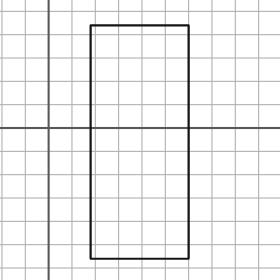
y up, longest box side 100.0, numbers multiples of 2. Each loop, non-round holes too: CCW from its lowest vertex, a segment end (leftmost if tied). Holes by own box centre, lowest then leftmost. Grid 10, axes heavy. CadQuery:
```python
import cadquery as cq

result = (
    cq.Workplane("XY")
    .moveTo(18.0, -56.0)
    .lineTo(60.0, -56.0)
    .lineTo(60.0, 44.0)
    .lineTo(18.0, 44.0)
    .close()
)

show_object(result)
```